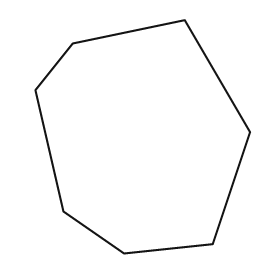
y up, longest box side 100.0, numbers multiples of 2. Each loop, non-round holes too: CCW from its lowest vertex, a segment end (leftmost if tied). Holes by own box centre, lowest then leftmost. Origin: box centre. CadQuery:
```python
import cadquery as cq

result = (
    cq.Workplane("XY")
    .moveTo(-8.0, -50.0)
    .lineTo(30.0, -46.0)
    .lineTo(46.0, 2.0)
    .lineTo(18.0, 50.0)
    .lineTo(-30.0, 40.0)
    .lineTo(-46.0, 20.0)
    .lineTo(-34.0, -32.0)
    .close()
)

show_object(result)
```